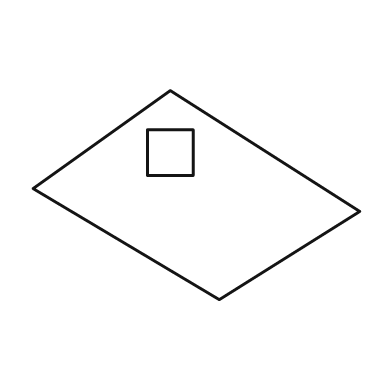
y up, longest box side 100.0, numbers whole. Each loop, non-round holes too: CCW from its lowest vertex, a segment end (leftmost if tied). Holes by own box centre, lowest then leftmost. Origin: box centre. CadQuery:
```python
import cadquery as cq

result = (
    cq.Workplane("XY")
    .moveTo(7.0, -32.0)
    .lineTo(50.0, -5.0)
    .lineTo(-8.0, 32.0)
    .lineTo(-50.0, 2.0)
    .close()
    .moveTo(-15.0, 6.0)
    .lineTo(-1.0, 6.0)
    .lineTo(-1.0, 20.0)
    .lineTo(-15.0, 20.0)
    .close()
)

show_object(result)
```